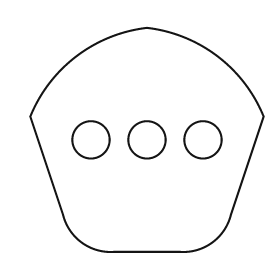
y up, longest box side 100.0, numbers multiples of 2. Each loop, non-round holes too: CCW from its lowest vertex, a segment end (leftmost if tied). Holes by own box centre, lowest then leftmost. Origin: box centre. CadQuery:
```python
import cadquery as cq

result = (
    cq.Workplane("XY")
    .moveTo(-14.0, -48.0)
    .lineTo(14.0, -48.0)
    .threePointArc((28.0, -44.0), (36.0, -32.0))
    .lineTo(50.0, 10.0)
    .threePointArc((30.0, 36.0), (0.0, 48.0))
    .threePointArc((-30.0, 36.0), (-50.0, 10.0))
    .lineTo(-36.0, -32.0)
    .threePointArc((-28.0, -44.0), (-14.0, -48.0))
    .close()
    .moveTo(-24.0, 0.0)
    .circle(8.0)
    .moveTo(0.0, 0.0)
    .circle(8.0)
    .moveTo(24.0, 0.0)
    .circle(8.0)
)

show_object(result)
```